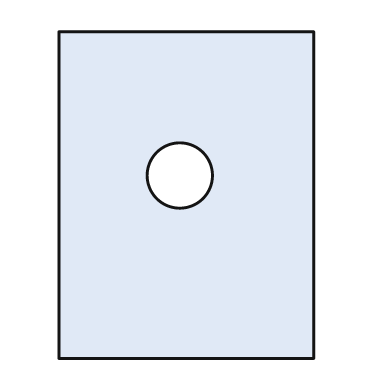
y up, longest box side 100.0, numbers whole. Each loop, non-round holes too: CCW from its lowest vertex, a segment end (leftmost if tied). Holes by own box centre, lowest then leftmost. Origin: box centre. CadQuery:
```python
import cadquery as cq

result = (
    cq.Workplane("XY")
    .moveTo(-39.0, -50.0)
    .lineTo(39.0, -50.0)
    .lineTo(39.0, 50.0)
    .lineTo(-39.0, 50.0)
    .close()
    .moveTo(-2.0, 6.0)
    .circle(10.0)
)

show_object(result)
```